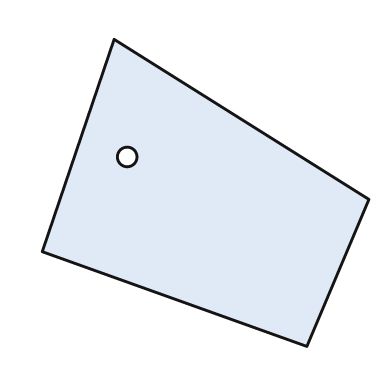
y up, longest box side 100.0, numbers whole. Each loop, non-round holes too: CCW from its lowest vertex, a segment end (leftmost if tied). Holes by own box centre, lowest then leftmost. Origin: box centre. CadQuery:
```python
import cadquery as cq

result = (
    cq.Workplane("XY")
    .moveTo(31.0, -47.0)
    .lineTo(50.0, -2.0)
    .lineTo(-28.0, 47.0)
    .lineTo(-50.0, -18.0)
    .close()
    .moveTo(-24.0, 11.0)
    .circle(3.0)
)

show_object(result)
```